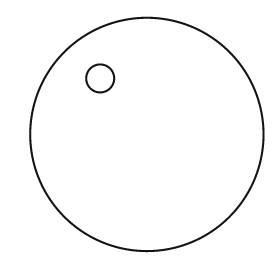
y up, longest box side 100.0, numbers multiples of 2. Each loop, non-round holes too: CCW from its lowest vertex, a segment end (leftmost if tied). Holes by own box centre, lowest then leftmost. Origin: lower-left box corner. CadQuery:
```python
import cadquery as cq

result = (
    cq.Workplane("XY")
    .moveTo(50.0, 50.0)
    .circle(50.0)
    .moveTo(30.0, 74.0)
    .circle(6.0)
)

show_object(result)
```